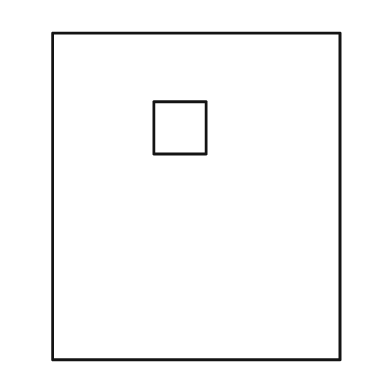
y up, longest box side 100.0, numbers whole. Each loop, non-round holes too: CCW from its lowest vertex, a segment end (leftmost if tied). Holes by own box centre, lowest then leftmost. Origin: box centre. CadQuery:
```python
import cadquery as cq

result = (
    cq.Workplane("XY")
    .moveTo(-44.0, -50.0)
    .lineTo(44.0, -50.0)
    .lineTo(44.0, 50.0)
    .lineTo(-44.0, 50.0)
    .close()
    .moveTo(-13.0, 13.0)
    .lineTo(3.0, 13.0)
    .lineTo(3.0, 29.0)
    .lineTo(-13.0, 29.0)
    .close()
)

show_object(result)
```